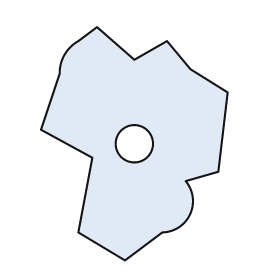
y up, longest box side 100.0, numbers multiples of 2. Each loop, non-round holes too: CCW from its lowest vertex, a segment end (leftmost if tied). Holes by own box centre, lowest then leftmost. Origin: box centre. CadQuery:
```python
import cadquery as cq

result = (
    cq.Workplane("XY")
    .moveTo(-4.0, -50.0)
    .lineTo(12.0, -38.0)
    .threePointArc((24.0, -30.0), (22.0, -16.0))
    .lineTo(36.0, -12.0)
    .lineTo(40.0, 22.0)
    .lineTo(24.0, 32.0)
    .lineTo(14.0, 44.0)
    .lineTo(0.0, 36.0)
    .lineTo(-16.0, 50.0)
    .lineTo(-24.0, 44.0)
    .threePointArc((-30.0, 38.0), (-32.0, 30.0))
    .lineTo(-40.0, 6.0)
    .lineTo(-18.0, -6.0)
    .lineTo(-24.0, -38.0)
    .close()
    .moveTo(0.0, 0.0)
    .circle(8.0)
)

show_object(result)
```